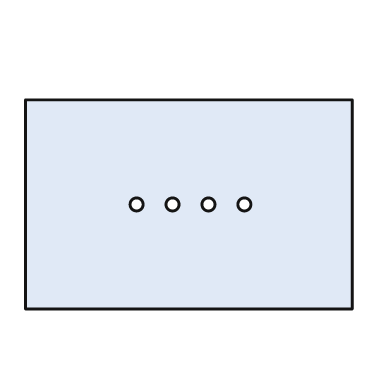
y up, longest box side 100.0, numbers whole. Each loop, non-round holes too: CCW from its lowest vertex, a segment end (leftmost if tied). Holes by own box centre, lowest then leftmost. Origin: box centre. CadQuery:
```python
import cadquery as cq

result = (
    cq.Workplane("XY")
    .moveTo(-50.0, -32.0)
    .lineTo(50.0, -32.0)
    .lineTo(50.0, 32.0)
    .lineTo(-50.0, 32.0)
    .close()
    .moveTo(-16.0, 0.0)
    .circle(2.0)
    .moveTo(-5.0, 0.0)
    .circle(2.0)
    .moveTo(6.0, 0.0)
    .circle(2.0)
    .moveTo(17.0, 0.0)
    .circle(2.0)
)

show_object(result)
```